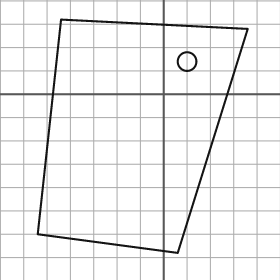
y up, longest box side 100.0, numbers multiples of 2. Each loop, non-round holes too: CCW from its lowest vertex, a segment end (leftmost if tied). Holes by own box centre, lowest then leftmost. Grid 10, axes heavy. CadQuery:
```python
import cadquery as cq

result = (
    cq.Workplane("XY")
    .moveTo(6.0, -68.0)
    .lineTo(36.0, 28.0)
    .lineTo(-44.0, 32.0)
    .lineTo(-54.0, -60.0)
    .close()
    .moveTo(10.0, 14.0)
    .circle(4.0)
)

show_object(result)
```